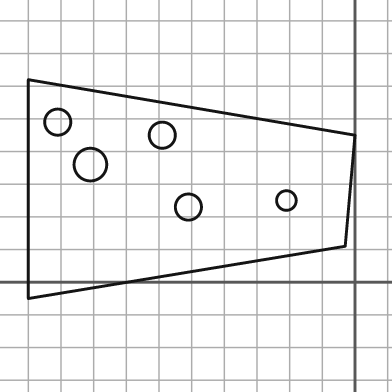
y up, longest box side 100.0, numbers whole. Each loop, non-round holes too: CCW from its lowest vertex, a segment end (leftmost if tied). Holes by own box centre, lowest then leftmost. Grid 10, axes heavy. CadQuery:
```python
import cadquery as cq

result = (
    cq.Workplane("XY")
    .moveTo(-100.0, -5.0)
    .lineTo(-3.0, 11.0)
    .lineTo(0.0, 45.0)
    .lineTo(-100.0, 62.0)
    .close()
    .moveTo(-51.0, 23.0)
    .circle(4.0)
    .moveTo(-21.0, 25.0)
    .circle(3.0)
    .moveTo(-81.0, 36.0)
    .circle(5.0)
    .moveTo(-59.0, 45.0)
    .circle(4.0)
    .moveTo(-91.0, 49.0)
    .circle(4.0)
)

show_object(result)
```